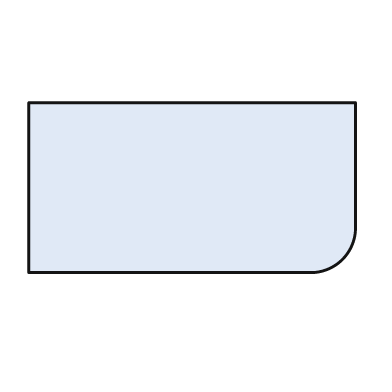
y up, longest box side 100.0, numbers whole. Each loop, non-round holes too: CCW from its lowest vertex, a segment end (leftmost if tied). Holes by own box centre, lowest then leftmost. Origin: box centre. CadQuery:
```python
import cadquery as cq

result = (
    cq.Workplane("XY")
    .moveTo(-50.0, -26.0)
    .lineTo(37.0, -26.0)
    .threePointArc((46.0, -22.0), (50.0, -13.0))
    .lineTo(50.0, 26.0)
    .lineTo(-50.0, 26.0)
    .close()
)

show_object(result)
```